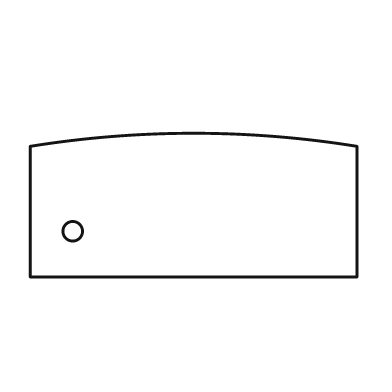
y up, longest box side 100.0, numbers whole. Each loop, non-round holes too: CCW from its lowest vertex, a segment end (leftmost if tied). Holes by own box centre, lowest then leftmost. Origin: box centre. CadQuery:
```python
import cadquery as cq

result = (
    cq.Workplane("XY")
    .moveTo(-50.0, -22.0)
    .lineTo(50.0, -22.0)
    .lineTo(50.0, 18.0)
    .threePointArc((0.0, 22.0), (-50.0, 18.0))
    .close()
    .moveTo(-37.0, -8.0)
    .circle(3.0)
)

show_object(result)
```